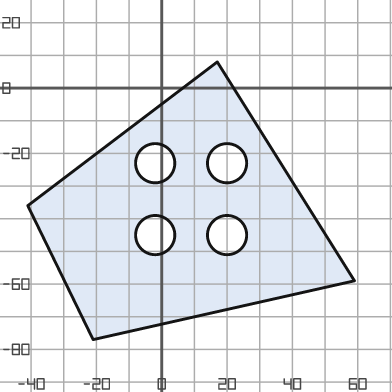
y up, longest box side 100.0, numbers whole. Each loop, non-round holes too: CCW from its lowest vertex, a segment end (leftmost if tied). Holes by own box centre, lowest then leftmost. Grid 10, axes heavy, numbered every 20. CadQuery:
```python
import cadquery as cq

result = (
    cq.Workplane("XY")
    .moveTo(-21.0, -77.0)
    .lineTo(59.0, -59.0)
    .lineTo(17.0, 8.0)
    .lineTo(-41.0, -36.0)
    .close()
    .moveTo(-2.0, -45.0)
    .circle(6.0)
    .moveTo(20.0, -45.0)
    .circle(6.0)
    .moveTo(-2.0, -23.0)
    .circle(6.0)
    .moveTo(20.0, -23.0)
    .circle(6.0)
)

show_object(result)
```